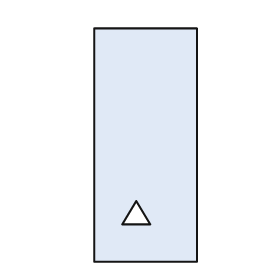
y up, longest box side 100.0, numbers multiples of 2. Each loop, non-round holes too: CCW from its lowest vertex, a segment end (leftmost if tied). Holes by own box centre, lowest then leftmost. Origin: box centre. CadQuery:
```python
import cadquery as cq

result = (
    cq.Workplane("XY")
    .moveTo(-22.0, -50.0)
    .lineTo(22.0, -50.0)
    .lineTo(22.0, 50.0)
    .lineTo(-22.0, 50.0)
    .close()
    .moveTo(-10.0, -34.0)
    .lineTo(2.0, -34.0)
    .lineTo(-4.0, -24.0)
    .close()
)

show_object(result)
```